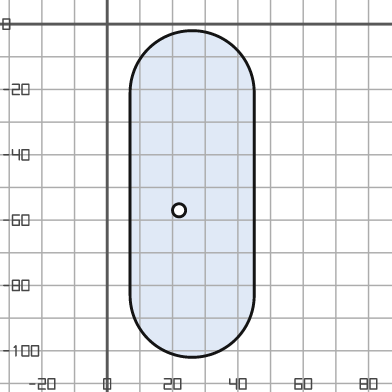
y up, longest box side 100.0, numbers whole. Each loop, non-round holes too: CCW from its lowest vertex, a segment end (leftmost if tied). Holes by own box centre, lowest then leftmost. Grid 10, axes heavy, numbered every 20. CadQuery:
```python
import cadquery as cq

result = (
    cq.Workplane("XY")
    .moveTo(7.0, -83.0)
    .threePointArc((26.0, -102.0), (45.0, -83.0))
    .lineTo(45.0, -21.0)
    .threePointArc((26.0, -2.0), (7.0, -21.0))
    .close()
    .moveTo(22.0, -57.0)
    .circle(2.0)
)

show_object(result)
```